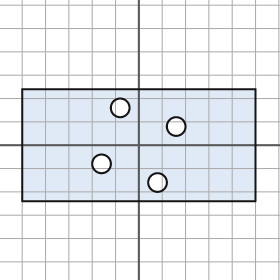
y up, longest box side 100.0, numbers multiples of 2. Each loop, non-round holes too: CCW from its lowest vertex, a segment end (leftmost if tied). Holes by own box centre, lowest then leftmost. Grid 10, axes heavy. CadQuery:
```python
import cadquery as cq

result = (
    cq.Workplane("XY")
    .moveTo(-50.0, -24.0)
    .lineTo(50.0, -24.0)
    .lineTo(50.0, 24.0)
    .lineTo(-50.0, 24.0)
    .close()
    .moveTo(8.0, -16.0)
    .circle(4.0)
    .moveTo(-16.0, -8.0)
    .circle(4.0)
    .moveTo(16.0, 8.0)
    .circle(4.0)
    .moveTo(-8.0, 16.0)
    .circle(4.0)
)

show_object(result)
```